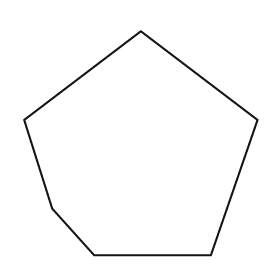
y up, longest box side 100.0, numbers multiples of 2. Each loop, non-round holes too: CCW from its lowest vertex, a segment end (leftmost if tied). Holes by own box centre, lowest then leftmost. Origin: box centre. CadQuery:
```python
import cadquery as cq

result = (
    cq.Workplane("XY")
    .moveTo(-20.0, -48.0)
    .lineTo(30.0, -48.0)
    .lineTo(50.0, 10.0)
    .lineTo(0.0, 48.0)
    .lineTo(-50.0, 10.0)
    .lineTo(-38.0, -28.0)
    .close()
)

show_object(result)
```